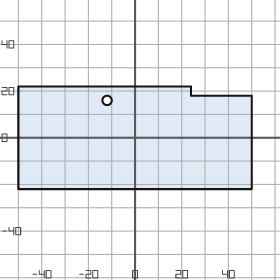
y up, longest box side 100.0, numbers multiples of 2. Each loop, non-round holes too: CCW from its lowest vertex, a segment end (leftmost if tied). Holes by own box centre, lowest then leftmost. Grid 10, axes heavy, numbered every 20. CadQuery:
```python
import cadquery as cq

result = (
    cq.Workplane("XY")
    .moveTo(-50.0, -22.0)
    .lineTo(50.0, -22.0)
    .lineTo(50.0, 18.0)
    .lineTo(24.0, 18.0)
    .lineTo(24.0, 22.0)
    .lineTo(-50.0, 22.0)
    .close()
    .moveTo(-12.0, 16.0)
    .circle(2.0)
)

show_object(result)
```